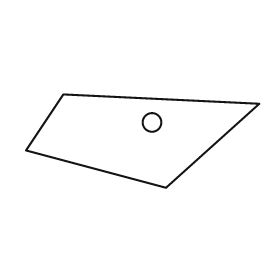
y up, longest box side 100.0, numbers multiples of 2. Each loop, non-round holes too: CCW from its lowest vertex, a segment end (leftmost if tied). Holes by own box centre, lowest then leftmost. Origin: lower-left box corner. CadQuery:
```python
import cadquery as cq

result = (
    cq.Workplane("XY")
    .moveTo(60.0, 0.0)
    .lineTo(100.0, 36.0)
    .lineTo(16.0, 40.0)
    .lineTo(0.0, 16.0)
    .close()
    .moveTo(54.0, 28.0)
    .circle(4.0)
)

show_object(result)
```